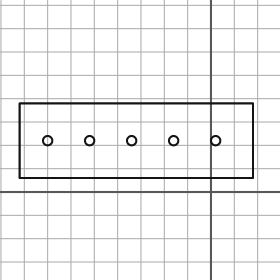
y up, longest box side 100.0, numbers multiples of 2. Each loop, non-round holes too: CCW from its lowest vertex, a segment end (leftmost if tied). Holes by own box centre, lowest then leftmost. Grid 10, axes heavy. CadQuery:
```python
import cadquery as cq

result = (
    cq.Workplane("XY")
    .moveTo(-82.0, 6.0)
    .lineTo(18.0, 6.0)
    .lineTo(18.0, 38.0)
    .lineTo(-82.0, 38.0)
    .close()
    .moveTo(-70.0, 22.0)
    .circle(2.0)
    .moveTo(-52.0, 22.0)
    .circle(2.0)
    .moveTo(-34.0, 22.0)
    .circle(2.0)
    .moveTo(-16.0, 22.0)
    .circle(2.0)
    .moveTo(2.0, 22.0)
    .circle(2.0)
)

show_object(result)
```